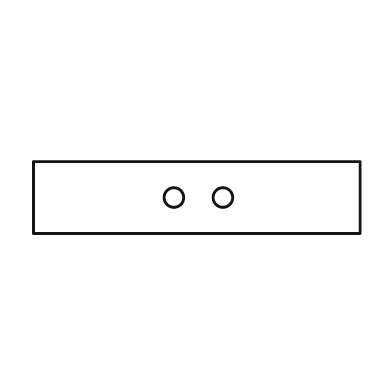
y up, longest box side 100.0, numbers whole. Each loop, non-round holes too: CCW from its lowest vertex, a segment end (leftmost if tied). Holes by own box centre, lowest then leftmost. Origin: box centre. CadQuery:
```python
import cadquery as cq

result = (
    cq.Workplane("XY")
    .moveTo(-50.0, -11.0)
    .lineTo(50.0, -11.0)
    .lineTo(50.0, 11.0)
    .lineTo(-50.0, 11.0)
    .close()
    .moveTo(-7.0, 0.0)
    .circle(3.0)
    .moveTo(8.0, 0.0)
    .circle(3.0)
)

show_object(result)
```